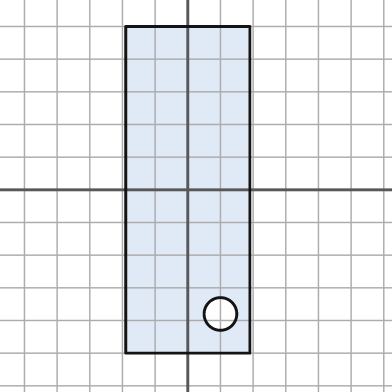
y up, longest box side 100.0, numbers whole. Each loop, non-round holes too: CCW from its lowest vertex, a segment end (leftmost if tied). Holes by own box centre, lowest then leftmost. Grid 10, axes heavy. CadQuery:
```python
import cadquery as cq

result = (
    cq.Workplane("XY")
    .moveTo(-19.0, -50.0)
    .lineTo(19.0, -50.0)
    .lineTo(19.0, 50.0)
    .lineTo(-19.0, 50.0)
    .close()
    .moveTo(10.0, -38.0)
    .circle(5.0)
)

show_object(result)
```